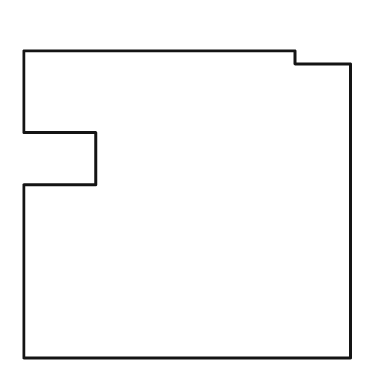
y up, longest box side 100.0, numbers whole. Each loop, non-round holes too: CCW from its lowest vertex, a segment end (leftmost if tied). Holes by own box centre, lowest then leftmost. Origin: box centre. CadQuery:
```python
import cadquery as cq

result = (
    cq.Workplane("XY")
    .moveTo(-50.0, -47.0)
    .lineTo(50.0, -47.0)
    .lineTo(50.0, 43.0)
    .lineTo(33.0, 43.0)
    .lineTo(33.0, 47.0)
    .lineTo(-50.0, 47.0)
    .lineTo(-50.0, 22.0)
    .lineTo(-28.0, 22.0)
    .lineTo(-28.0, 6.0)
    .lineTo(-50.0, 6.0)
    .close()
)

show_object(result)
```